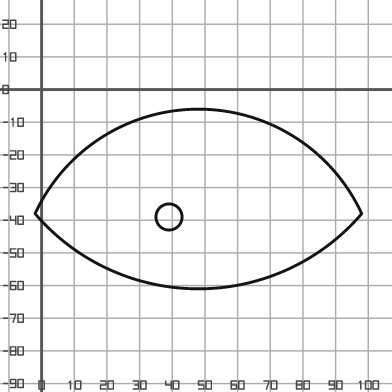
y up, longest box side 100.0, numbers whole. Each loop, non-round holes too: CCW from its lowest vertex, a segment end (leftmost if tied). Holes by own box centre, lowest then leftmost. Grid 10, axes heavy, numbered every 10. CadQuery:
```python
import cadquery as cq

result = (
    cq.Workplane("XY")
    .moveTo(-2.0, -38.0)
    .threePointArc((48.0, -61.0), (98.0, -38.0))
    .threePointArc((48.0, -6.0), (-2.0, -38.0))
    .close()
    .moveTo(39.0, -39.0)
    .circle(4.0)
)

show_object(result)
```